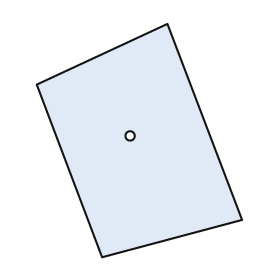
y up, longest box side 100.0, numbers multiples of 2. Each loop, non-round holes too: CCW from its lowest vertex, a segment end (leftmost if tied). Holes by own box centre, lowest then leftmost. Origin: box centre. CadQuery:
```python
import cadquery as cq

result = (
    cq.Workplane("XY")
    .moveTo(-16.0, -50.0)
    .lineTo(44.0, -34.0)
    .lineTo(12.0, 50.0)
    .lineTo(-44.0, 24.0)
    .close()
    .moveTo(-4.0, 2.0)
    .circle(2.0)
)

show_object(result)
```